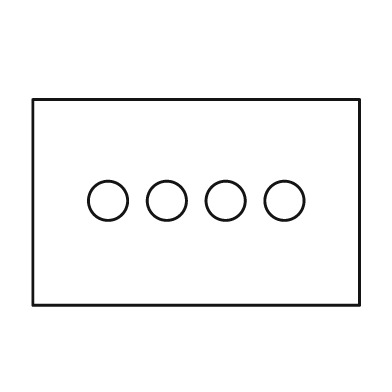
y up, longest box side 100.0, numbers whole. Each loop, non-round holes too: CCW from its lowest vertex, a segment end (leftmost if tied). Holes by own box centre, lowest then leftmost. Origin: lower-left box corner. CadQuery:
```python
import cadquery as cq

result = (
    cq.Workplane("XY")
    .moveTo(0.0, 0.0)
    .lineTo(100.0, 0.0)
    .lineTo(100.0, 63.0)
    .lineTo(0.0, 63.0)
    .close()
    .moveTo(23.0, 32.0)
    .circle(6.0)
    .moveTo(41.0, 32.0)
    .circle(6.0)
    .moveTo(59.0, 32.0)
    .circle(6.0)
    .moveTo(77.0, 32.0)
    .circle(6.0)
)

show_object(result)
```